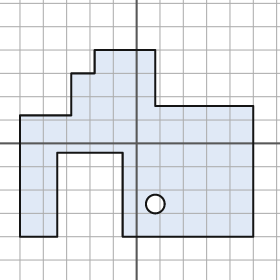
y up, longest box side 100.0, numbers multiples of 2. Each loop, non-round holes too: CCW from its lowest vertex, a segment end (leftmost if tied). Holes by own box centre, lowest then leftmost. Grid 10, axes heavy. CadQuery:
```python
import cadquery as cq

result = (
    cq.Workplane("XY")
    .moveTo(-50.0, -40.0)
    .lineTo(-34.0, -40.0)
    .lineTo(-34.0, -4.0)
    .lineTo(-6.0, -4.0)
    .lineTo(-6.0, -40.0)
    .lineTo(50.0, -40.0)
    .lineTo(50.0, 16.0)
    .lineTo(8.0, 16.0)
    .lineTo(8.0, 40.0)
    .lineTo(-18.0, 40.0)
    .lineTo(-18.0, 30.0)
    .lineTo(-28.0, 30.0)
    .lineTo(-28.0, 12.0)
    .lineTo(-50.0, 12.0)
    .close()
    .moveTo(8.0, -26.0)
    .circle(4.0)
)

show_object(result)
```